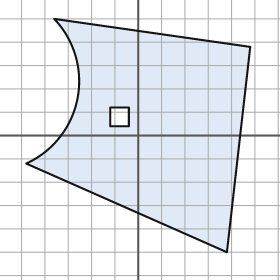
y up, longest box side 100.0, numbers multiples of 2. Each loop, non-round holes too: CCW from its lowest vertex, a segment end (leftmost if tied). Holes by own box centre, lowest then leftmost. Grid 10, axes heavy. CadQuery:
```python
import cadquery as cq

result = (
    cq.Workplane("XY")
    .moveTo(38.0, -50.0)
    .lineTo(48.0, 38.0)
    .lineTo(-36.0, 50.0)
    .threePointArc((-26.0, 16.0), (-48.0, -12.0))
    .close()
    .moveTo(-12.0, 4.0)
    .lineTo(-4.0, 4.0)
    .lineTo(-4.0, 12.0)
    .lineTo(-12.0, 12.0)
    .close()
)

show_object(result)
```